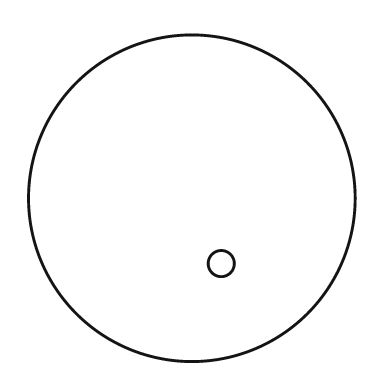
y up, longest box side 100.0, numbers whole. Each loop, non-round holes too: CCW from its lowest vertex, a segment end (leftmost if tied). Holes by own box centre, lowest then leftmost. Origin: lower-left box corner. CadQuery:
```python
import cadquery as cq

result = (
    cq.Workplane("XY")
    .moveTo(50.0, 50.0)
    .circle(50.0)
    .moveTo(59.0, 30.0)
    .circle(4.0)
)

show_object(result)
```